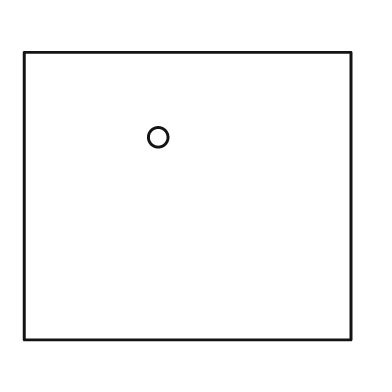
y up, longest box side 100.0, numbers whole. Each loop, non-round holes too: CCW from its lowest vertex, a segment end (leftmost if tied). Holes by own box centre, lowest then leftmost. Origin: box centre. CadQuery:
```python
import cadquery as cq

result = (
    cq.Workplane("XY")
    .moveTo(-50.0, -44.0)
    .lineTo(50.0, -44.0)
    .lineTo(50.0, 44.0)
    .lineTo(-50.0, 44.0)
    .close()
    .moveTo(-9.0, 18.0)
    .circle(3.0)
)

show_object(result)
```